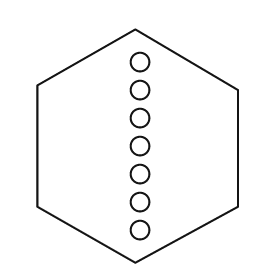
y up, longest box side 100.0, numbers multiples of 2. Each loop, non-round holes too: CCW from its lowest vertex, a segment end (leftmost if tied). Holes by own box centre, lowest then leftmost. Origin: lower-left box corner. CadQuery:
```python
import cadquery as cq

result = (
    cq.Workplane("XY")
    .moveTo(42.0, 0.0)
    .lineTo(86.0, 24.0)
    .lineTo(86.0, 74.0)
    .lineTo(42.0, 100.0)
    .lineTo(0.0, 76.0)
    .lineTo(0.0, 24.0)
    .close()
    .moveTo(44.0, 14.0)
    .circle(4.0)
    .moveTo(44.0, 26.0)
    .circle(4.0)
    .moveTo(44.0, 38.0)
    .circle(4.0)
    .moveTo(44.0, 50.0)
    .circle(4.0)
    .moveTo(44.0, 62.0)
    .circle(4.0)
    .moveTo(44.0, 74.0)
    .circle(4.0)
    .moveTo(44.0, 86.0)
    .circle(4.0)
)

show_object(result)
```